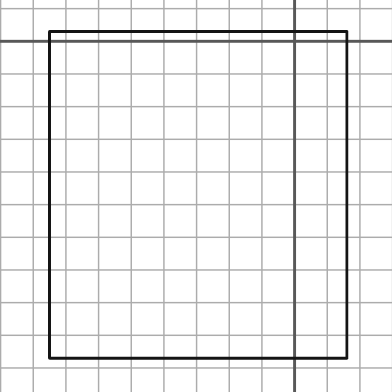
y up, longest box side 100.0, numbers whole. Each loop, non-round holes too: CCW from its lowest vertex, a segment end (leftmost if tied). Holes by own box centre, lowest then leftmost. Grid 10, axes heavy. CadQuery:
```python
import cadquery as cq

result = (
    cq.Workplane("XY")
    .moveTo(-75.0, -97.0)
    .lineTo(16.0, -97.0)
    .lineTo(16.0, 3.0)
    .lineTo(-75.0, 3.0)
    .close()
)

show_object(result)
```